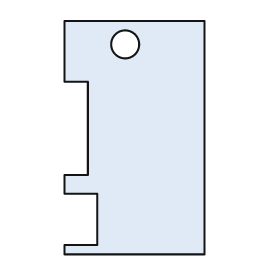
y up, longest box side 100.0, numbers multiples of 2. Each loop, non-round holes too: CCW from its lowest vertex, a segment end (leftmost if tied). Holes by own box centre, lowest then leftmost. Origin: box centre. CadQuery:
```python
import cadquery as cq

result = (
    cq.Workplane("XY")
    .moveTo(-30.0, -50.0)
    .lineTo(30.0, -50.0)
    .lineTo(30.0, 50.0)
    .lineTo(-30.0, 50.0)
    .lineTo(-30.0, 24.0)
    .lineTo(-20.0, 24.0)
    .lineTo(-20.0, -16.0)
    .lineTo(-30.0, -16.0)
    .lineTo(-30.0, -24.0)
    .lineTo(-16.0, -24.0)
    .lineTo(-16.0, -46.0)
    .lineTo(-30.0, -46.0)
    .close()
    .moveTo(-4.0, 40.0)
    .circle(6.0)
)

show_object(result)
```